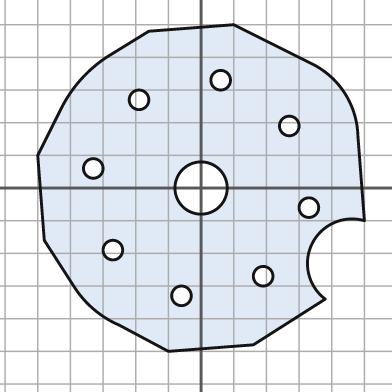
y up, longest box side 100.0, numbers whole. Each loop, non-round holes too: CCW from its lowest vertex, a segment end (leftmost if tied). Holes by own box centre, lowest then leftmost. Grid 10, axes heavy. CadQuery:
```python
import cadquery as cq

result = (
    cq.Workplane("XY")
    .moveTo(-10.0, -50.0)
    .lineTo(16.0, -48.0)
    .lineTo(38.0, -34.0)
    .threePointArc((34.0, -17.0), (50.0, -10.0))
    .lineTo(48.0, 16.0)
    .threePointArc((44.0, 29.0), (34.0, 38.0))
    .lineTo(10.0, 50.0)
    .lineTo(-16.0, 48.0)
    .lineTo(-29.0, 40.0)
    .threePointArc((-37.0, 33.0), (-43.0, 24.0))
    .lineTo(-50.0, 10.0)
    .lineTo(-48.0, -16.0)
    .lineTo(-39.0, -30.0)
    .threePointArc((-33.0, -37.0), (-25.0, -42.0))
    .close()
    .moveTo(-6.0, -33.0)
    .circle(3.0)
    .moveTo(19.0, -27.0)
    .circle(3.0)
    .moveTo(-27.0, -19.0)
    .circle(3.0)
    .moveTo(33.0, -6.0)
    .circle(3.0)
    .moveTo(0.0, 0.0)
    .circle(8.0)
    .moveTo(-33.0, 6.0)
    .circle(3.0)
    .moveTo(27.0, 19.0)
    .circle(3.0)
    .moveTo(-19.0, 27.0)
    .circle(3.0)
    .moveTo(6.0, 33.0)
    .circle(3.0)
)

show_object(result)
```